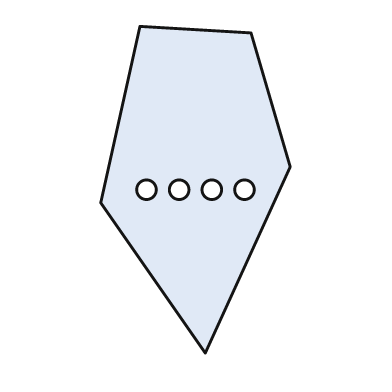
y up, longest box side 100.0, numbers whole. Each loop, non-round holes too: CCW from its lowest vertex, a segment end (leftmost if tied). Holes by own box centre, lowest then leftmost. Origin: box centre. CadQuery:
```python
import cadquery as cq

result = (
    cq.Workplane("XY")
    .moveTo(3.0, -50.0)
    .lineTo(29.0, 7.0)
    .lineTo(17.0, 48.0)
    .lineTo(-17.0, 50.0)
    .lineTo(-29.0, -4.0)
    .close()
    .moveTo(-15.0, 0.0)
    .circle(3.0)
    .moveTo(-5.0, 0.0)
    .circle(3.0)
    .moveTo(5.0, 0.0)
    .circle(3.0)
    .moveTo(15.0, 0.0)
    .circle(3.0)
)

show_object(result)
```